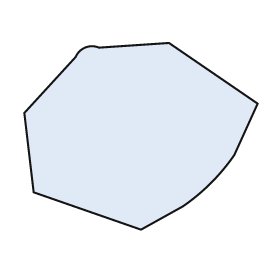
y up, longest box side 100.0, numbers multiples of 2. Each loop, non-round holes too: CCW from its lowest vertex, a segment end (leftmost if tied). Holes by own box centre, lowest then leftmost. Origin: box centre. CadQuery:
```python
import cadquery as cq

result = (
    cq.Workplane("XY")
    .moveTo(0.0, -40.0)
    .lineTo(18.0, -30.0)
    .threePointArc((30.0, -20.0), (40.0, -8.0))
    .lineTo(50.0, 14.0)
    .lineTo(12.0, 40.0)
    .lineTo(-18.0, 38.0)
    .threePointArc((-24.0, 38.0), (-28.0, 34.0))
    .lineTo(-50.0, 10.0)
    .lineTo(-46.0, -24.0)
    .close()
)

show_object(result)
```